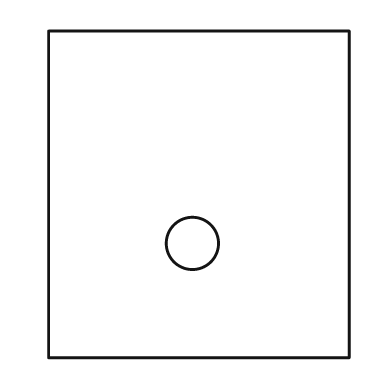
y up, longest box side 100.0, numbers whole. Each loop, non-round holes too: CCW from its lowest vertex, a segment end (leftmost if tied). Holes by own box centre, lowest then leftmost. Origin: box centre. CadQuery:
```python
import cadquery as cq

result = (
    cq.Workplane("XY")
    .moveTo(-46.0, -50.0)
    .lineTo(46.0, -50.0)
    .lineTo(46.0, 50.0)
    .lineTo(-46.0, 50.0)
    .close()
    .moveTo(-2.0, -15.0)
    .circle(8.0)
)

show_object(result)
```